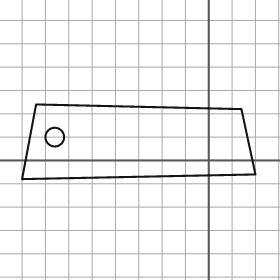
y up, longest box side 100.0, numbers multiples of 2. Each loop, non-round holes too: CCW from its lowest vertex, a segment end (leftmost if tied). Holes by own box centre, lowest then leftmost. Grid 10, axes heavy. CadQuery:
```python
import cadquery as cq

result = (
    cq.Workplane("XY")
    .moveTo(-80.0, -8.0)
    .lineTo(20.0, -6.0)
    .lineTo(14.0, 22.0)
    .lineTo(-74.0, 24.0)
    .close()
    .moveTo(-66.0, 10.0)
    .circle(4.0)
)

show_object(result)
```